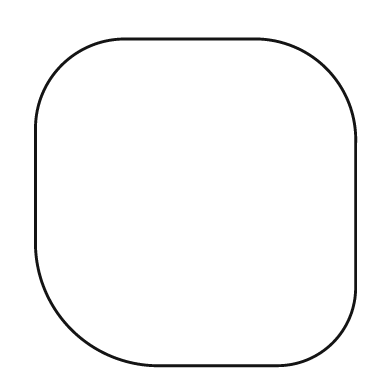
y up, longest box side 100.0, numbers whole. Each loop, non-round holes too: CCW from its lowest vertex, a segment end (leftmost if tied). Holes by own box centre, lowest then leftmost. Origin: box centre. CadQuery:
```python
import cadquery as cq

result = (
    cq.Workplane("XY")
    .moveTo(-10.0, -50.0)
    .lineTo(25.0, -50.0)
    .threePointArc((42.0, -43.0), (49.0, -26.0))
    .lineTo(49.0, 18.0)
    .threePointArc((40.0, 41.0), (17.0, 50.0))
    .lineTo(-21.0, 50.0)
    .threePointArc((-41.0, 42.0), (-49.0, 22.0))
    .lineTo(-49.0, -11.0)
    .threePointArc((-38.0, -39.0), (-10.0, -50.0))
    .close()
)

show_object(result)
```